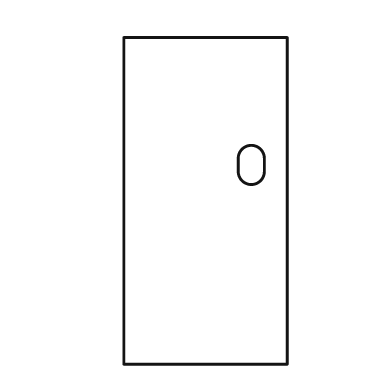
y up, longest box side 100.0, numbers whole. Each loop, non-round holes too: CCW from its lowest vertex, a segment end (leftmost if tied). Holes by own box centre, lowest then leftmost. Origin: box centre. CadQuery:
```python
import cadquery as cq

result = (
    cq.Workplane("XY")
    .moveTo(-25.0, -50.0)
    .lineTo(25.0, -50.0)
    .lineTo(25.0, 50.0)
    .lineTo(-25.0, 50.0)
    .close()
    .moveTo(10.0, 9.0)
    .threePointArc((14.0, 5.0), (18.0, 9.0))
    .lineTo(18.0, 13.0)
    .threePointArc((14.0, 17.0), (10.0, 13.0))
    .close()
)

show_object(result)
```